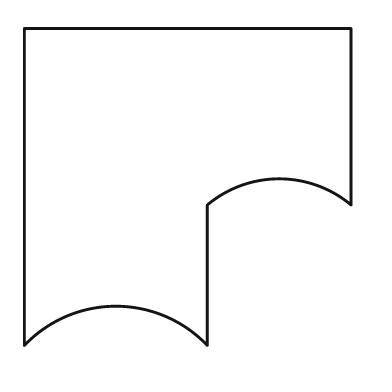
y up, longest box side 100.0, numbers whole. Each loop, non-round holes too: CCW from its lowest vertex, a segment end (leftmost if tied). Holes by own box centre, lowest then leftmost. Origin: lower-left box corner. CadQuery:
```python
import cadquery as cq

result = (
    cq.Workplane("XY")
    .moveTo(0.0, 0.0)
    .threePointArc((28.0, 12.0), (56.0, 0.0))
    .lineTo(56.0, 43.0)
    .threePointArc((78.0, 51.0), (100.0, 43.0))
    .lineTo(100.0, 97.0)
    .lineTo(0.0, 97.0)
    .close()
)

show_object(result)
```